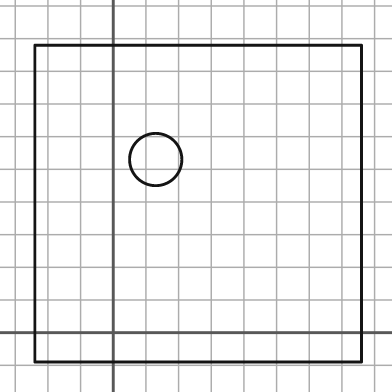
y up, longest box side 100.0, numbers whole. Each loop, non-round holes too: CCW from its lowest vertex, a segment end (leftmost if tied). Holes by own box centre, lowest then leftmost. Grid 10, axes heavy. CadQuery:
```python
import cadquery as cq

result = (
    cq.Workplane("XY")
    .moveTo(-24.0, -9.0)
    .lineTo(76.0, -9.0)
    .lineTo(76.0, 88.0)
    .lineTo(-24.0, 88.0)
    .close()
    .moveTo(13.0, 53.0)
    .circle(8.0)
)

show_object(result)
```